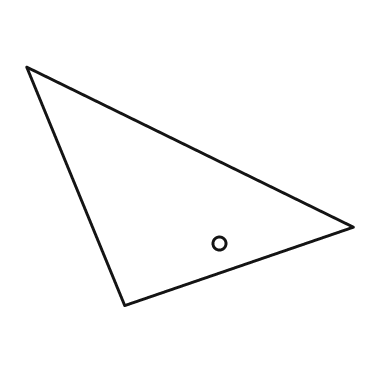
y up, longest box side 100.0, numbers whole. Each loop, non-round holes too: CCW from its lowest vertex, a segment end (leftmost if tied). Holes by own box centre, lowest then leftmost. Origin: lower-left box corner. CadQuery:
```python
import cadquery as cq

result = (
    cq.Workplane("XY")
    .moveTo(30.0, 0.0)
    .lineTo(100.0, 24.0)
    .lineTo(0.0, 73.0)
    .close()
    .moveTo(59.0, 19.0)
    .circle(2.0)
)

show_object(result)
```